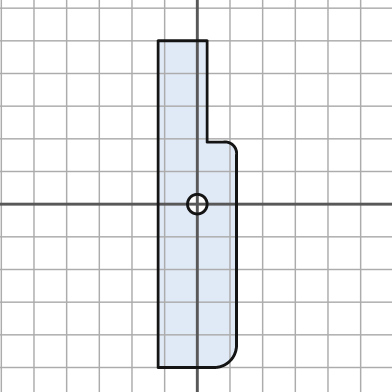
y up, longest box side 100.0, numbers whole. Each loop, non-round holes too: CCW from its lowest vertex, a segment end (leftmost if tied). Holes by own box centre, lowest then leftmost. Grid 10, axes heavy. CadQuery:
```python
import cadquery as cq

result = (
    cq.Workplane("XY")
    .moveTo(-12.0, -50.0)
    .lineTo(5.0, -50.0)
    .threePointArc((10.0, -48.0), (12.0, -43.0))
    .lineTo(12.0, 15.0)
    .threePointArc((11.0, 18.0), (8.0, 19.0))
    .lineTo(3.0, 19.0)
    .lineTo(3.0, 50.0)
    .lineTo(-12.0, 50.0)
    .close()
    .moveTo(0.0, 0.0)
    .circle(3.0)
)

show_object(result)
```